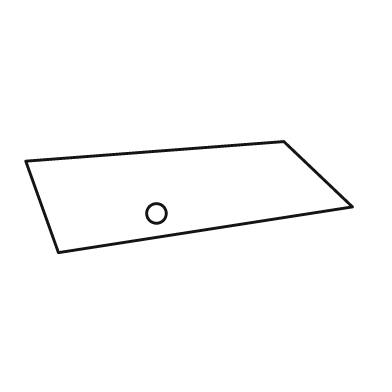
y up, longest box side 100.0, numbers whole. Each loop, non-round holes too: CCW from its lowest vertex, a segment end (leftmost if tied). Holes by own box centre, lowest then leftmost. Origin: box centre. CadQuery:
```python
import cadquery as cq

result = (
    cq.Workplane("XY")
    .moveTo(-40.0, -17.0)
    .lineTo(50.0, -3.0)
    .lineTo(29.0, 17.0)
    .lineTo(-50.0, 11.0)
    .close()
    .moveTo(-10.0, -5.0)
    .circle(3.0)
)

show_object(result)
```